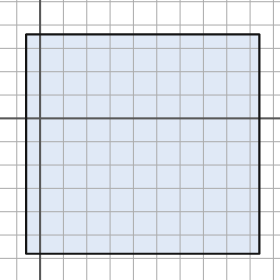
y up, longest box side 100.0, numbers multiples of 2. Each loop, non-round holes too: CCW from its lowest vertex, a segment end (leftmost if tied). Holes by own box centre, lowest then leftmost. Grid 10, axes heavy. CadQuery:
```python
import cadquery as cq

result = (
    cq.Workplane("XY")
    .moveTo(-6.0, -58.0)
    .lineTo(94.0, -58.0)
    .lineTo(94.0, 36.0)
    .lineTo(-6.0, 36.0)
    .close()
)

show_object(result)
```